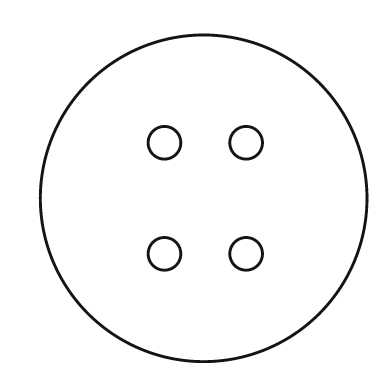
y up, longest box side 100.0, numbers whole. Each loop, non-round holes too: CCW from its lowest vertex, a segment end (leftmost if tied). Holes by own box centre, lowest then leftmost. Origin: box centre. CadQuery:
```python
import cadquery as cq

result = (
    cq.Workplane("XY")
    .moveTo(0.0, 0.0)
    .circle(50.0)
    .moveTo(-12.0, -17.0)
    .circle(5.0)
    .moveTo(13.0, -17.0)
    .circle(5.0)
    .moveTo(-12.0, 17.0)
    .circle(5.0)
    .moveTo(13.0, 17.0)
    .circle(5.0)
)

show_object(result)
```